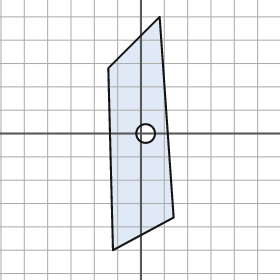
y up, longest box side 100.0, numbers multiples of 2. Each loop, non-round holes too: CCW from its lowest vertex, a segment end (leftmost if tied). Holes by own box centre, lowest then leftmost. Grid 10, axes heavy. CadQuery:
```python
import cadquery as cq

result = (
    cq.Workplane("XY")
    .moveTo(-12.0, -50.0)
    .lineTo(14.0, -36.0)
    .lineTo(8.0, 50.0)
    .lineTo(-14.0, 28.0)
    .close()
    .moveTo(2.0, 0.0)
    .circle(4.0)
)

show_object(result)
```